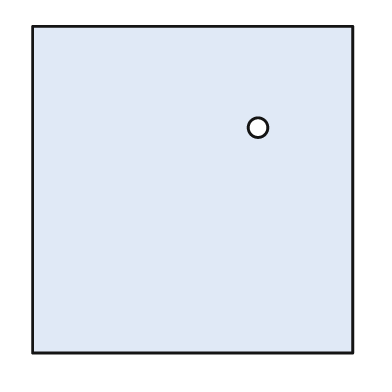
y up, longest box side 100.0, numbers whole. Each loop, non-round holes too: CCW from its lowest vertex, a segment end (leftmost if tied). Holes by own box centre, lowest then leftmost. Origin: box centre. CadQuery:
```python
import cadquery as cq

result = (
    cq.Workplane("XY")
    .moveTo(-49.0, -50.0)
    .lineTo(49.0, -50.0)
    .lineTo(49.0, 50.0)
    .lineTo(-49.0, 50.0)
    .close()
    .moveTo(20.0, 19.0)
    .circle(3.0)
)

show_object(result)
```